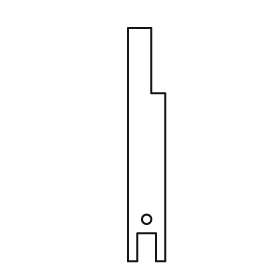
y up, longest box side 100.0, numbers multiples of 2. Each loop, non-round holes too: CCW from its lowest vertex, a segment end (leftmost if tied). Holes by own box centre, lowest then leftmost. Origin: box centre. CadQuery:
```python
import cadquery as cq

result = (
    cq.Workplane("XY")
    .moveTo(-8.0, -50.0)
    .lineTo(-4.0, -50.0)
    .lineTo(-4.0, -38.0)
    .lineTo(4.0, -38.0)
    .lineTo(4.0, -50.0)
    .lineTo(8.0, -50.0)
    .lineTo(8.0, 22.0)
    .lineTo(2.0, 22.0)
    .lineTo(2.0, 50.0)
    .lineTo(-8.0, 50.0)
    .close()
    .moveTo(0.0, -32.0)
    .circle(2.0)
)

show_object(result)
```